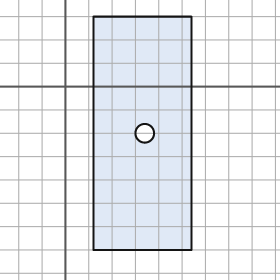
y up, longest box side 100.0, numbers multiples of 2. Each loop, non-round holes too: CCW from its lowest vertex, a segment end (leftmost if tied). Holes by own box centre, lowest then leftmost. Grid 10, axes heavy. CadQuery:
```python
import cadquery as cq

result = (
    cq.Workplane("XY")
    .moveTo(12.0, -70.0)
    .lineTo(54.0, -70.0)
    .lineTo(54.0, 30.0)
    .lineTo(12.0, 30.0)
    .close()
    .moveTo(34.0, -20.0)
    .circle(4.0)
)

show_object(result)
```